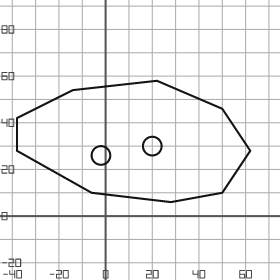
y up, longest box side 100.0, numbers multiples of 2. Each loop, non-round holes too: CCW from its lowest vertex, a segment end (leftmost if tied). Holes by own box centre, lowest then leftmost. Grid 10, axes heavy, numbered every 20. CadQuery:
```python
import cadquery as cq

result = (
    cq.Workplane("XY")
    .moveTo(28.0, 6.0)
    .lineTo(50.0, 10.0)
    .lineTo(62.0, 28.0)
    .lineTo(50.0, 46.0)
    .lineTo(22.0, 58.0)
    .lineTo(-14.0, 54.0)
    .lineTo(-38.0, 42.0)
    .lineTo(-38.0, 28.0)
    .lineTo(-6.0, 10.0)
    .close()
    .moveTo(-2.0, 26.0)
    .circle(4.0)
    .moveTo(20.0, 30.0)
    .circle(4.0)
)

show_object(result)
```